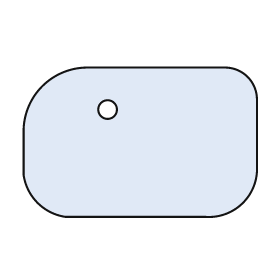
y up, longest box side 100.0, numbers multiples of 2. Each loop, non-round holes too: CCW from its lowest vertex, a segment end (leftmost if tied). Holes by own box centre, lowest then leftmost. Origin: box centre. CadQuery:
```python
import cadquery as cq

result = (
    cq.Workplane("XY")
    .moveTo(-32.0, -32.0)
    .lineTo(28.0, -32.0)
    .threePointArc((44.0, -26.0), (50.0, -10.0))
    .lineTo(50.0, 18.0)
    .threePointArc((46.0, 28.0), (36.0, 32.0))
    .lineTo(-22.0, 32.0)
    .threePointArc((-42.0, 24.0), (-50.0, 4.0))
    .lineTo(-50.0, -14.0)
    .threePointArc((-44.0, -26.0), (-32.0, -32.0))
    .close()
    .moveTo(-14.0, 14.0)
    .circle(4.0)
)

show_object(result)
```